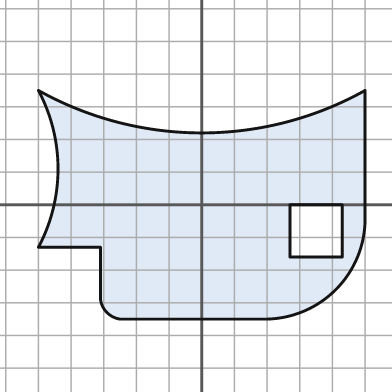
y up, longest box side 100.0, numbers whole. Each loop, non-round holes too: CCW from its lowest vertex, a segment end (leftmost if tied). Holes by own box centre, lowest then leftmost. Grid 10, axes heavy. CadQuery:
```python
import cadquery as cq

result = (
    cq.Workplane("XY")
    .moveTo(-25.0, -35.0)
    .lineTo(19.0, -35.0)
    .threePointArc((41.0, -26.0), (50.0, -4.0))
    .lineTo(50.0, 35.0)
    .threePointArc((0.0, 22.0), (-50.0, 35.0))
    .threePointArc((-44.0, 11.0), (-50.0, -13.0))
    .lineTo(-31.0, -13.0)
    .lineTo(-31.0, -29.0)
    .threePointArc((-29.0, -33.0), (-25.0, -35.0))
    .close()
    .moveTo(27.0, -16.0)
    .lineTo(43.0, -16.0)
    .lineTo(43.0, 0.0)
    .lineTo(27.0, 0.0)
    .close()
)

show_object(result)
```